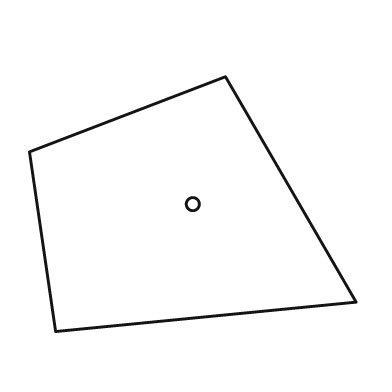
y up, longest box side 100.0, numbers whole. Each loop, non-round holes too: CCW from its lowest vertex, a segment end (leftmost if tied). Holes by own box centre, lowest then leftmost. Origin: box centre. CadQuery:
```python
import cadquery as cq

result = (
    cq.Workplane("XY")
    .moveTo(-42.0, -39.0)
    .lineTo(50.0, -30.0)
    .lineTo(10.0, 39.0)
    .lineTo(-50.0, 16.0)
    .close()
    .moveTo(0.0, 0.0)
    .circle(2.0)
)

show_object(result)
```